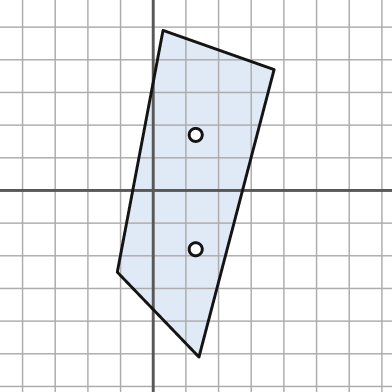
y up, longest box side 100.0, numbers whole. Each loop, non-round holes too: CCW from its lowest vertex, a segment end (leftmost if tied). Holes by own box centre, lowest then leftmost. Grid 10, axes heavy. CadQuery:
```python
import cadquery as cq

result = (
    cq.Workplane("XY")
    .moveTo(14.0, -51.0)
    .lineTo(37.0, 37.0)
    .lineTo(3.0, 49.0)
    .lineTo(-11.0, -25.0)
    .close()
    .moveTo(13.0, -18.0)
    .circle(2.0)
    .moveTo(13.0, 17.0)
    .circle(2.0)
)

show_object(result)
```